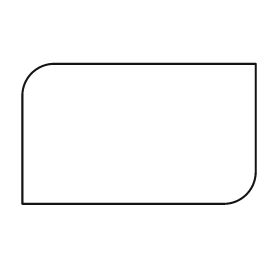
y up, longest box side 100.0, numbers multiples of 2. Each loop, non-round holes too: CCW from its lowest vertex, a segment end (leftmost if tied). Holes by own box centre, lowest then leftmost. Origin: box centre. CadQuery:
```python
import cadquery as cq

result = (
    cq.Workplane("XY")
    .moveTo(-50.0, -30.0)
    .lineTo(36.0, -30.0)
    .threePointArc((46.0, -26.0), (50.0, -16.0))
    .lineTo(50.0, 30.0)
    .lineTo(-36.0, 30.0)
    .threePointArc((-46.0, 26.0), (-50.0, 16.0))
    .close()
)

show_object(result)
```